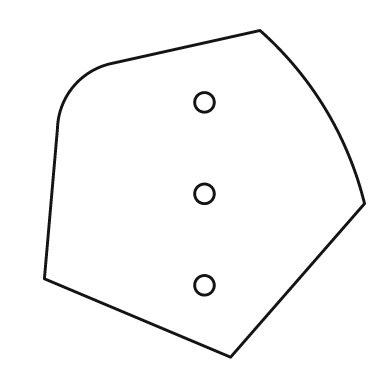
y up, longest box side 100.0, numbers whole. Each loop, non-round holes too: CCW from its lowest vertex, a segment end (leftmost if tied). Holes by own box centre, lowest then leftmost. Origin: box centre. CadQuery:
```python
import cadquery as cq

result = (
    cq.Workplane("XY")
    .moveTo(8.0, -50.0)
    .lineTo(49.0, -3.0)
    .threePointArc((37.0, 26.0), (17.0, 50.0))
    .lineTo(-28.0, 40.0)
    .threePointArc((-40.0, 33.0), (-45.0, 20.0))
    .lineTo(-49.0, -26.0)
    .close()
    .moveTo(0.0, -28.0)
    .circle(3.0)
    .moveTo(0.0, 0.0)
    .circle(3.0)
    .moveTo(0.0, 28.0)
    .circle(3.0)
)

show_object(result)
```